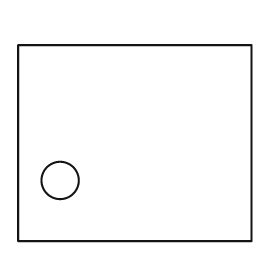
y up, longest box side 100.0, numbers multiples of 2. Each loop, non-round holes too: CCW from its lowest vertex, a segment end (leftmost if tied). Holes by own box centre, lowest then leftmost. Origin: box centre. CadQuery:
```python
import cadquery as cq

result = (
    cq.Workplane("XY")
    .moveTo(-50.0, -42.0)
    .lineTo(50.0, -42.0)
    .lineTo(50.0, 42.0)
    .lineTo(-50.0, 42.0)
    .close()
    .moveTo(-32.0, -16.0)
    .circle(8.0)
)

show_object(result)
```